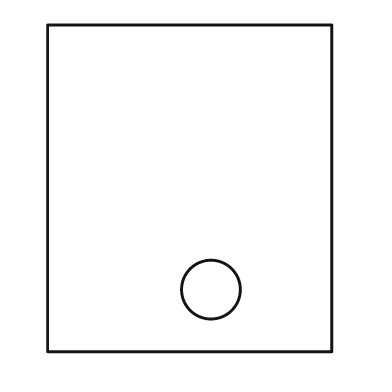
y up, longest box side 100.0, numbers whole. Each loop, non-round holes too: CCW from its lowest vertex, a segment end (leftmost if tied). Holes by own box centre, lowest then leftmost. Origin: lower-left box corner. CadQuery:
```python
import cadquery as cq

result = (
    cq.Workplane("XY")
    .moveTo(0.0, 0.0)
    .lineTo(87.0, 0.0)
    .lineTo(87.0, 100.0)
    .lineTo(0.0, 100.0)
    .close()
    .moveTo(50.0, 19.0)
    .circle(9.0)
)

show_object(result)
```